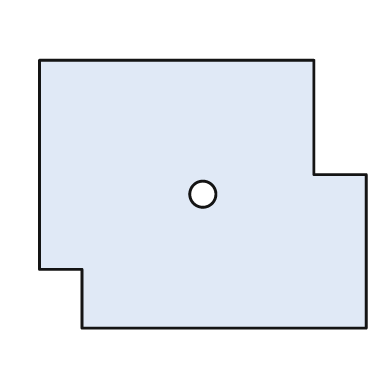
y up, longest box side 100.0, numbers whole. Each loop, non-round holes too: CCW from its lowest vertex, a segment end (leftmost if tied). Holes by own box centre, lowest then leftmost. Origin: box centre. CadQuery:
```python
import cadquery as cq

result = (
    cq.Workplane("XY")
    .moveTo(-37.0, -41.0)
    .lineTo(50.0, -41.0)
    .lineTo(50.0, 6.0)
    .lineTo(34.0, 6.0)
    .lineTo(34.0, 41.0)
    .lineTo(-50.0, 41.0)
    .lineTo(-50.0, -23.0)
    .lineTo(-37.0, -23.0)
    .close()
    .moveTo(0.0, 0.0)
    .circle(4.0)
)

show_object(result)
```